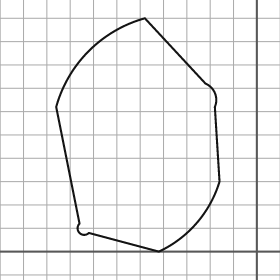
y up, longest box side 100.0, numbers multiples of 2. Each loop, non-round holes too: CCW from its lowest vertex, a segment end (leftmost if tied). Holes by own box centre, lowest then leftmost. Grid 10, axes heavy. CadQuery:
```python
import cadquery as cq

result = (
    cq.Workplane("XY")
    .moveTo(-42.0, 0.0)
    .threePointArc((-26.0, 12.0), (-16.0, 30.0))
    .lineTo(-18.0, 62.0)
    .threePointArc((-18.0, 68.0), (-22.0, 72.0))
    .lineTo(-48.0, 100.0)
    .threePointArc((-72.0, 86.0), (-86.0, 62.0))
    .lineTo(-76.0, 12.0)
    .threePointArc((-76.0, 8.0), (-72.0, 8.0))
    .close()
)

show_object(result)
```